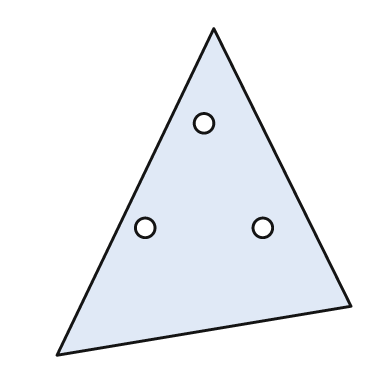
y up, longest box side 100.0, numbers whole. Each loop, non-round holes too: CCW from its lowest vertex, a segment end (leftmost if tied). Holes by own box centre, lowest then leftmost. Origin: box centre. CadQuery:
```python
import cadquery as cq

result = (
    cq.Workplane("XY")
    .moveTo(-45.0, -50.0)
    .lineTo(45.0, -35.0)
    .lineTo(3.0, 50.0)
    .close()
    .moveTo(-18.0, -11.0)
    .circle(3.0)
    .moveTo(18.0, -11.0)
    .circle(3.0)
    .moveTo(0.0, 21.0)
    .circle(3.0)
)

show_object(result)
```